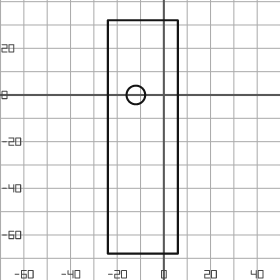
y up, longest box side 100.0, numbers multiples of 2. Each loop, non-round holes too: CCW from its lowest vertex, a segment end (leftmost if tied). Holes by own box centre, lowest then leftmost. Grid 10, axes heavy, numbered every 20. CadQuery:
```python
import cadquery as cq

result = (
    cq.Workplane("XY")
    .moveTo(-24.0, -68.0)
    .lineTo(6.0, -68.0)
    .lineTo(6.0, 32.0)
    .lineTo(-24.0, 32.0)
    .close()
    .moveTo(-12.0, 0.0)
    .circle(4.0)
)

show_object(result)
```